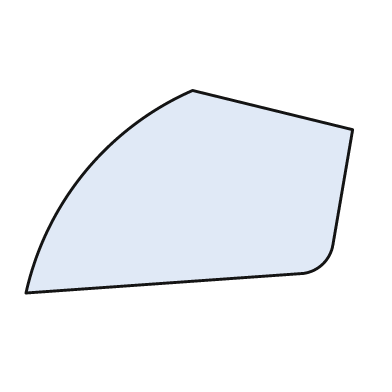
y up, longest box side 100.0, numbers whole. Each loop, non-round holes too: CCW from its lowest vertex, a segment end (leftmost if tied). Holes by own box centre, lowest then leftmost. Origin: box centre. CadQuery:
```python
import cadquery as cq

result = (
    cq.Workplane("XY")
    .moveTo(-50.0, -31.0)
    .lineTo(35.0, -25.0)
    .threePointArc((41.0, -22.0), (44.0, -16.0))
    .lineTo(50.0, 19.0)
    .lineTo(1.0, 31.0)
    .threePointArc((-32.0, 6.0), (-50.0, -31.0))
    .close()
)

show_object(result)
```